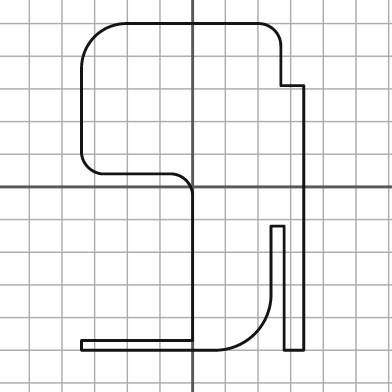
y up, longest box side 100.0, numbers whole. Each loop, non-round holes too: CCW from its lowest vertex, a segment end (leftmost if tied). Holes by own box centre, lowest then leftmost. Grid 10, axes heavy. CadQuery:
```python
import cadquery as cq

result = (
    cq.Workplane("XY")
    .moveTo(-34.0, -50.0)
    .lineTo(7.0, -50.0)
    .threePointArc((19.0, -45.0), (24.0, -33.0))
    .lineTo(24.0, -12.0)
    .lineTo(28.0, -12.0)
    .lineTo(28.0, -50.0)
    .lineTo(34.0, -50.0)
    .lineTo(34.0, 31.0)
    .lineTo(27.0, 31.0)
    .lineTo(27.0, 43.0)
    .threePointArc((25.0, 48.0), (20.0, 50.0))
    .lineTo(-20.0, 50.0)
    .threePointArc((-30.0, 46.0), (-34.0, 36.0))
    .lineTo(-34.0, 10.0)
    .threePointArc((-32.0, 6.0), (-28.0, 4.0))
    .lineTo(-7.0, 4.0)
    .threePointArc((-2.0, 2.0), (0.0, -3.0))
    .lineTo(0.0, -47.0)
    .lineTo(-34.0, -47.0)
    .close()
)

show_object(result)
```